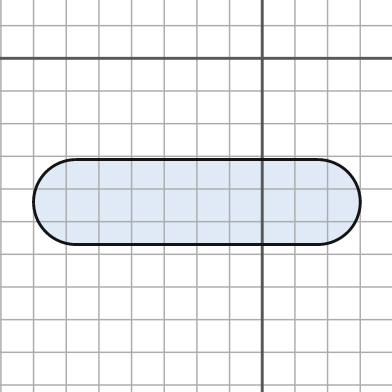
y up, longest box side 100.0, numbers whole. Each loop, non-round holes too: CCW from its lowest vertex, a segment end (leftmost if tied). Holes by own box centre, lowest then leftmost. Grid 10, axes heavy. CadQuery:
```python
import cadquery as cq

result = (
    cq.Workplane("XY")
    .moveTo(-57.0, -57.0)
    .lineTo(17.0, -57.0)
    .threePointArc((30.0, -44.0), (17.0, -31.0))
    .lineTo(-57.0, -31.0)
    .threePointArc((-70.0, -44.0), (-57.0, -57.0))
    .close()
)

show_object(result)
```